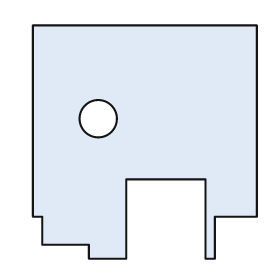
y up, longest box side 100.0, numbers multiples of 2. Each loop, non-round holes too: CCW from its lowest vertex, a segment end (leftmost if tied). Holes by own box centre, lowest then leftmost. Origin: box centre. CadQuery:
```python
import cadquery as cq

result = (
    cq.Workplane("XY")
    .moveTo(-24.0, -50.0)
    .lineTo(-8.0, -50.0)
    .lineTo(-8.0, -16.0)
    .lineTo(26.0, -16.0)
    .lineTo(26.0, -50.0)
    .lineTo(30.0, -50.0)
    .lineTo(30.0, -32.0)
    .lineTo(48.0, -32.0)
    .lineTo(48.0, 50.0)
    .lineTo(-48.0, 50.0)
    .lineTo(-48.0, -32.0)
    .lineTo(-44.0, -32.0)
    .lineTo(-44.0, -44.0)
    .lineTo(-24.0, -44.0)
    .close()
    .moveTo(-20.0, 10.0)
    .circle(8.0)
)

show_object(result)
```